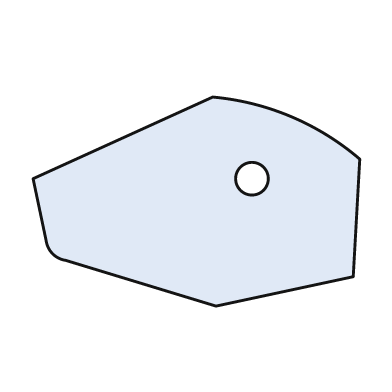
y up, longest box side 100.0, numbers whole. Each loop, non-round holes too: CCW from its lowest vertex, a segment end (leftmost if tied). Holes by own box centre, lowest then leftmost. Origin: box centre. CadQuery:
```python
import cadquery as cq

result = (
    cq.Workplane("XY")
    .moveTo(6.0, -32.0)
    .lineTo(48.0, -23.0)
    .lineTo(50.0, 13.0)
    .threePointArc((29.0, 26.0), (5.0, 32.0))
    .lineTo(-50.0, 7.0)
    .lineTo(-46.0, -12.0)
    .threePointArc((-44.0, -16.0), (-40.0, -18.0))
    .close()
    .moveTo(17.0, 7.0)
    .circle(5.0)
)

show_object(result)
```